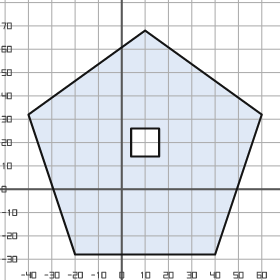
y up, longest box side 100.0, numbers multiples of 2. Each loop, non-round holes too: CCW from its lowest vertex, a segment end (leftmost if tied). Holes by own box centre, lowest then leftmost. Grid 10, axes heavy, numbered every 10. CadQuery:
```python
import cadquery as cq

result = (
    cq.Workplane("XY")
    .moveTo(-20.0, -28.0)
    .lineTo(40.0, -28.0)
    .lineTo(60.0, 32.0)
    .lineTo(10.0, 68.0)
    .lineTo(-40.0, 32.0)
    .close()
    .moveTo(4.0, 14.0)
    .lineTo(16.0, 14.0)
    .lineTo(16.0, 26.0)
    .lineTo(4.0, 26.0)
    .close()
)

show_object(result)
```